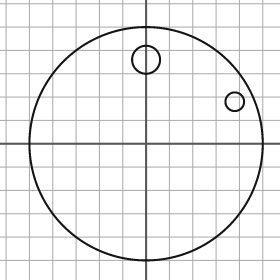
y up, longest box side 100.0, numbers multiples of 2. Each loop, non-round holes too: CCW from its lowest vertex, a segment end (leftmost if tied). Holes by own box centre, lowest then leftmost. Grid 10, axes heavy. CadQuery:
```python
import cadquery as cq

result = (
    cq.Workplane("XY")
    .moveTo(0.0, 0.0)
    .circle(50.0)
    .moveTo(38.0, 18.0)
    .circle(4.0)
    .moveTo(0.0, 36.0)
    .circle(6.0)
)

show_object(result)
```